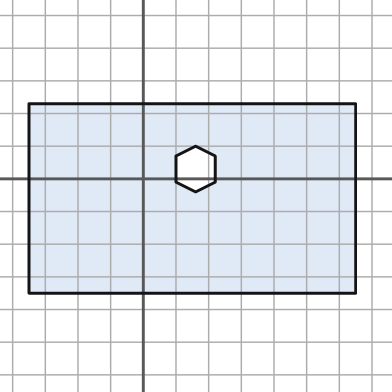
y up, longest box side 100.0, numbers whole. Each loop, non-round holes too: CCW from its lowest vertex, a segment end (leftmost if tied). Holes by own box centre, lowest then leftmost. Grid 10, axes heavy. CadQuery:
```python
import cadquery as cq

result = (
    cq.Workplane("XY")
    .moveTo(-35.0, -35.0)
    .lineTo(65.0, -35.0)
    .lineTo(65.0, 23.0)
    .lineTo(-35.0, 23.0)
    .close()
    .moveTo(16.0, -4.0)
    .lineTo(22.0, -1.0)
    .lineTo(22.0, 7.0)
    .lineTo(16.0, 10.0)
    .lineTo(10.0, 7.0)
    .lineTo(10.0, -1.0)
    .close()
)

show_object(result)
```